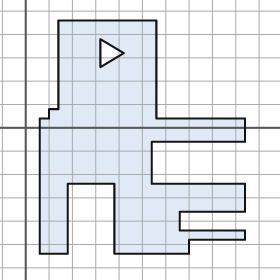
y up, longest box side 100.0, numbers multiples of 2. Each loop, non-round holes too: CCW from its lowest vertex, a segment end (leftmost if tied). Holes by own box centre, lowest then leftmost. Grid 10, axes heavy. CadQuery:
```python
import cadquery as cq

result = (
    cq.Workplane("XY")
    .moveTo(6.0, -54.0)
    .lineTo(18.0, -54.0)
    .lineTo(18.0, -24.0)
    .lineTo(38.0, -24.0)
    .lineTo(38.0, -54.0)
    .lineTo(70.0, -54.0)
    .lineTo(70.0, -48.0)
    .lineTo(94.0, -48.0)
    .lineTo(94.0, -44.0)
    .lineTo(66.0, -44.0)
    .lineTo(66.0, -36.0)
    .lineTo(94.0, -36.0)
    .lineTo(94.0, -24.0)
    .lineTo(54.0, -24.0)
    .lineTo(54.0, -6.0)
    .lineTo(94.0, -6.0)
    .lineTo(94.0, 4.0)
    .lineTo(56.0, 4.0)
    .lineTo(56.0, 46.0)
    .lineTo(14.0, 46.0)
    .lineTo(14.0, 8.0)
    .lineTo(10.0, 8.0)
    .lineTo(10.0, 4.0)
    .lineTo(6.0, 4.0)
    .close()
    .moveTo(32.0, 26.0)
    .lineTo(42.0, 32.0)
    .lineTo(32.0, 38.0)
    .close()
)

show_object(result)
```